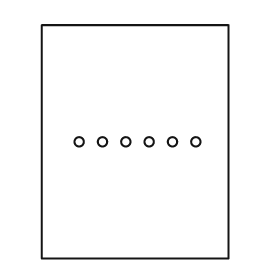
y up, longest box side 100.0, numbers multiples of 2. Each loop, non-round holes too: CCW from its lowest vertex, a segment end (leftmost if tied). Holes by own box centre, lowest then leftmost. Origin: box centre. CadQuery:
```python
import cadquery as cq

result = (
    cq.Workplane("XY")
    .moveTo(-40.0, -50.0)
    .lineTo(40.0, -50.0)
    .lineTo(40.0, 50.0)
    .lineTo(-40.0, 50.0)
    .close()
    .moveTo(-24.0, 0.0)
    .circle(2.0)
    .moveTo(-14.0, 0.0)
    .circle(2.0)
    .moveTo(-4.0, 0.0)
    .circle(2.0)
    .moveTo(6.0, 0.0)
    .circle(2.0)
    .moveTo(16.0, 0.0)
    .circle(2.0)
    .moveTo(26.0, 0.0)
    .circle(2.0)
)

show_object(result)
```